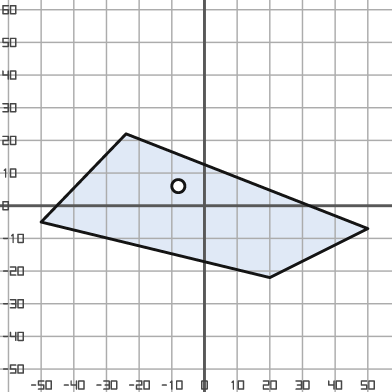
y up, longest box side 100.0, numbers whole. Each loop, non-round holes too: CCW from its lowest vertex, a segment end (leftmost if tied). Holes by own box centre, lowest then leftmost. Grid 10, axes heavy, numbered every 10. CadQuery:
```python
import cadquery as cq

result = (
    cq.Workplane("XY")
    .moveTo(20.0, -22.0)
    .lineTo(50.0, -7.0)
    .lineTo(-24.0, 22.0)
    .lineTo(-50.0, -5.0)
    .close()
    .moveTo(-8.0, 6.0)
    .circle(2.0)
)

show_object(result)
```